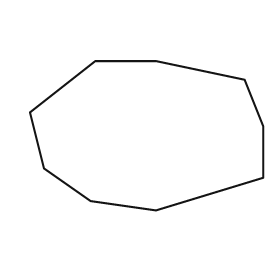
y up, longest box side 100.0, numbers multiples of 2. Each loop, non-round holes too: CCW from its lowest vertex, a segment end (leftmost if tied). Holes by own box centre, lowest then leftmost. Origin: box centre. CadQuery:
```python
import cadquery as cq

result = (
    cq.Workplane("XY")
    .moveTo(4.0, -32.0)
    .lineTo(50.0, -18.0)
    .lineTo(50.0, 4.0)
    .lineTo(42.0, 24.0)
    .lineTo(4.0, 32.0)
    .lineTo(-22.0, 32.0)
    .lineTo(-50.0, 10.0)
    .lineTo(-44.0, -14.0)
    .lineTo(-24.0, -28.0)
    .close()
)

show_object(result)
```